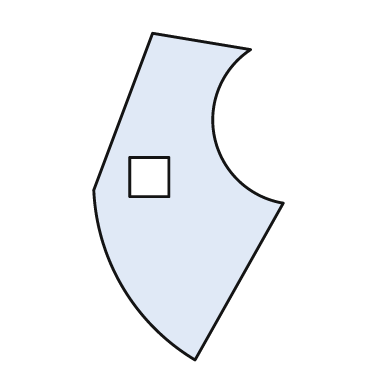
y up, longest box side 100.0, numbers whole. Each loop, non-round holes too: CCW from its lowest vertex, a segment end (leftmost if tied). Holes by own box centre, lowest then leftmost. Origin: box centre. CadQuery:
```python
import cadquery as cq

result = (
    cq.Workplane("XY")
    .moveTo(2.0, -50.0)
    .lineTo(29.0, -2.0)
    .threePointArc((8.0, 18.0), (19.0, 45.0))
    .lineTo(-11.0, 50.0)
    .lineTo(-29.0, 2.0)
    .threePointArc((-20.0, -28.0), (2.0, -50.0))
    .close()
    .moveTo(-18.0, 0.0)
    .lineTo(-6.0, 0.0)
    .lineTo(-6.0, 12.0)
    .lineTo(-18.0, 12.0)
    .close()
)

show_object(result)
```